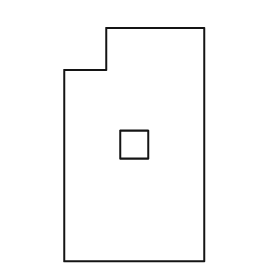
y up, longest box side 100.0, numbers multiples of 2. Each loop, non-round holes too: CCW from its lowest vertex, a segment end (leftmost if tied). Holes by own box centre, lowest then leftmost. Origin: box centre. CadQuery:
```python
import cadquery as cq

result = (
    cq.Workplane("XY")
    .moveTo(-30.0, -50.0)
    .lineTo(30.0, -50.0)
    .lineTo(30.0, 50.0)
    .lineTo(-12.0, 50.0)
    .lineTo(-12.0, 32.0)
    .lineTo(-30.0, 32.0)
    .close()
    .moveTo(-6.0, -6.0)
    .lineTo(6.0, -6.0)
    .lineTo(6.0, 6.0)
    .lineTo(-6.0, 6.0)
    .close()
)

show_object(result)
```